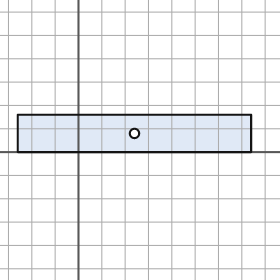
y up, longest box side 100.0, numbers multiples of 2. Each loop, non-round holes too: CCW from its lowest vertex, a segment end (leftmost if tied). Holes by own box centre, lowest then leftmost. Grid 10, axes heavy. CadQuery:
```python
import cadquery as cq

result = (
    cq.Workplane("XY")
    .moveTo(-26.0, 0.0)
    .lineTo(74.0, 0.0)
    .lineTo(74.0, 16.0)
    .lineTo(-26.0, 16.0)
    .close()
    .moveTo(24.0, 8.0)
    .circle(2.0)
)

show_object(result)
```